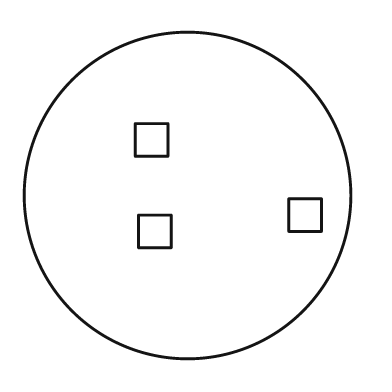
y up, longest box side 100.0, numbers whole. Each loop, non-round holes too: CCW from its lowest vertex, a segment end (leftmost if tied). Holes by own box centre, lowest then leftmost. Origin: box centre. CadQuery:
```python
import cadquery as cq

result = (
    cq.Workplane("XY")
    .moveTo(0.0, 0.0)
    .circle(50.0)
    .moveTo(-15.0, -16.0)
    .lineTo(-5.0, -16.0)
    .lineTo(-5.0, -6.0)
    .lineTo(-15.0, -6.0)
    .close()
    .moveTo(31.0, -11.0)
    .lineTo(41.0, -11.0)
    .lineTo(41.0, -1.0)
    .lineTo(31.0, -1.0)
    .close()
    .moveTo(-16.0, 12.0)
    .lineTo(-6.0, 12.0)
    .lineTo(-6.0, 22.0)
    .lineTo(-16.0, 22.0)
    .close()
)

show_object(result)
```